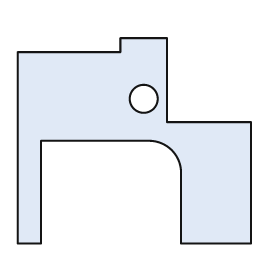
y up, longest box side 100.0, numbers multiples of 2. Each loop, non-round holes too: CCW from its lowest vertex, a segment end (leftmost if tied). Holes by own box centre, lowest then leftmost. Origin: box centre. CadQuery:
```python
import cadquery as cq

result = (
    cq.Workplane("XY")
    .moveTo(-50.0, -44.0)
    .lineTo(-40.0, -44.0)
    .lineTo(-40.0, 0.0)
    .lineTo(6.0, 0.0)
    .threePointArc((16.0, -4.0), (20.0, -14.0))
    .lineTo(20.0, -44.0)
    .lineTo(50.0, -44.0)
    .lineTo(50.0, 8.0)
    .lineTo(14.0, 8.0)
    .lineTo(14.0, 44.0)
    .lineTo(-6.0, 44.0)
    .lineTo(-6.0, 38.0)
    .lineTo(-50.0, 38.0)
    .close()
    .moveTo(4.0, 18.0)
    .circle(6.0)
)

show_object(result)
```